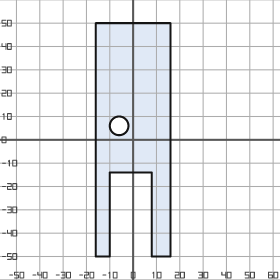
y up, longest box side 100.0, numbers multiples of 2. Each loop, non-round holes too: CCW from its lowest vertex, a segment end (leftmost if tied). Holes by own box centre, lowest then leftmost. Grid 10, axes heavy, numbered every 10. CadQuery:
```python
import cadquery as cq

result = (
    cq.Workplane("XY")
    .moveTo(-16.0, -50.0)
    .lineTo(-10.0, -50.0)
    .lineTo(-10.0, -14.0)
    .lineTo(8.0, -14.0)
    .lineTo(8.0, -50.0)
    .lineTo(16.0, -50.0)
    .lineTo(16.0, 50.0)
    .lineTo(-16.0, 50.0)
    .close()
    .moveTo(-6.0, 6.0)
    .circle(4.0)
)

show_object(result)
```